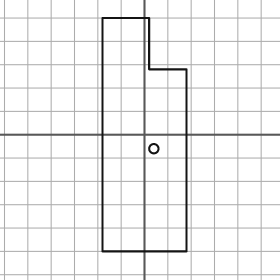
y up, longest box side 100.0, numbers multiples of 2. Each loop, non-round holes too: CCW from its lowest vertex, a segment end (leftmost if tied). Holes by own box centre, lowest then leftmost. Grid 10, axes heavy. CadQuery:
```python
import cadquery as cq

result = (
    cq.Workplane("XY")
    .moveTo(-18.0, -50.0)
    .lineTo(18.0, -50.0)
    .lineTo(18.0, 28.0)
    .lineTo(2.0, 28.0)
    .lineTo(2.0, 50.0)
    .lineTo(-18.0, 50.0)
    .close()
    .moveTo(4.0, -6.0)
    .circle(2.0)
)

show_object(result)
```